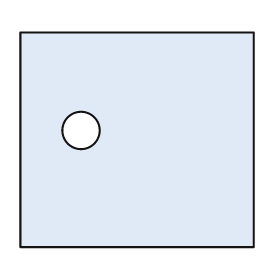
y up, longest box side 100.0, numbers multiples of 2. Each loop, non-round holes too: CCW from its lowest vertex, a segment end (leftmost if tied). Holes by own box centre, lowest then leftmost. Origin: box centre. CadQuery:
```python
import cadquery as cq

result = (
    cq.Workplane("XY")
    .moveTo(-50.0, -46.0)
    .lineTo(50.0, -46.0)
    .lineTo(50.0, 46.0)
    .lineTo(-50.0, 46.0)
    .close()
    .moveTo(-24.0, 4.0)
    .circle(8.0)
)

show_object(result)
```